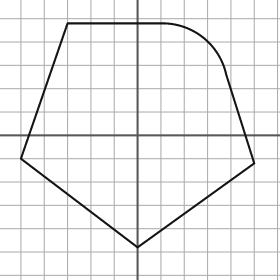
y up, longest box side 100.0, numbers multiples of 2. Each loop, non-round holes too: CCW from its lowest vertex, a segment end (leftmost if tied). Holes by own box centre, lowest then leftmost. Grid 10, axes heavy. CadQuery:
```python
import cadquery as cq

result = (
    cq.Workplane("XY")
    .moveTo(0.0, -48.0)
    .lineTo(50.0, -12.0)
    .lineTo(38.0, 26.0)
    .threePointArc((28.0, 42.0), (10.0, 48.0))
    .lineTo(-30.0, 48.0)
    .lineTo(-50.0, -10.0)
    .close()
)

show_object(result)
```